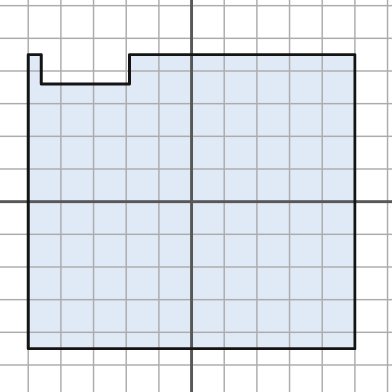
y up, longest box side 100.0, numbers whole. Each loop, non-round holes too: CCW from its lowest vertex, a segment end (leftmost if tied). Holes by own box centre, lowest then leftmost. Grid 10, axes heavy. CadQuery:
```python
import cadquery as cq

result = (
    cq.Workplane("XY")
    .moveTo(-50.0, -45.0)
    .lineTo(50.0, -45.0)
    .lineTo(50.0, 45.0)
    .lineTo(-19.0, 45.0)
    .lineTo(-19.0, 36.0)
    .lineTo(-46.0, 36.0)
    .lineTo(-46.0, 45.0)
    .lineTo(-50.0, 45.0)
    .close()
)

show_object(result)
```